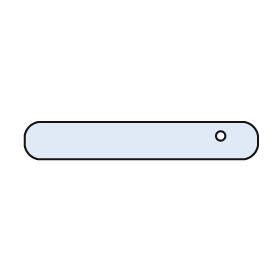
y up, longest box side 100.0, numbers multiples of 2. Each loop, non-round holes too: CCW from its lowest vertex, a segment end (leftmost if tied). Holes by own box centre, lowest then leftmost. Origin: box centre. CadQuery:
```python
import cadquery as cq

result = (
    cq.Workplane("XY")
    .moveTo(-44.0, -8.0)
    .lineTo(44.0, -8.0)
    .threePointArc((48.0, -6.0), (50.0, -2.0))
    .lineTo(50.0, 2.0)
    .threePointArc((48.0, 6.0), (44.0, 8.0))
    .lineTo(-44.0, 8.0)
    .threePointArc((-48.0, 6.0), (-50.0, 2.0))
    .lineTo(-50.0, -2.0)
    .threePointArc((-48.0, -6.0), (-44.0, -8.0))
    .close()
    .moveTo(34.0, 2.0)
    .circle(2.0)
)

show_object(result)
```